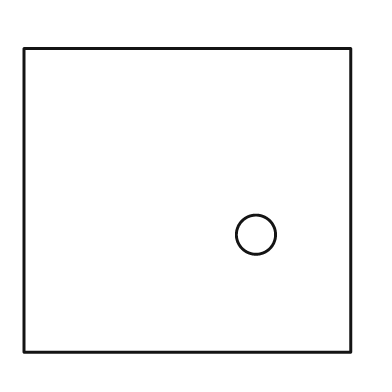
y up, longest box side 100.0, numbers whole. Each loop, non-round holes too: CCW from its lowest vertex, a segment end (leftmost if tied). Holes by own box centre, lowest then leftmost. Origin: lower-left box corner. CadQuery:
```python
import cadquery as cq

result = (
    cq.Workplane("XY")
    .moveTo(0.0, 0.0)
    .lineTo(100.0, 0.0)
    .lineTo(100.0, 93.0)
    .lineTo(0.0, 93.0)
    .close()
    .moveTo(71.0, 36.0)
    .circle(6.0)
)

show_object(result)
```